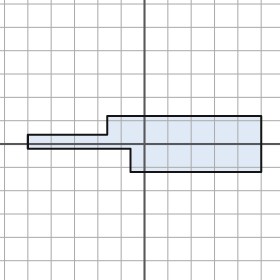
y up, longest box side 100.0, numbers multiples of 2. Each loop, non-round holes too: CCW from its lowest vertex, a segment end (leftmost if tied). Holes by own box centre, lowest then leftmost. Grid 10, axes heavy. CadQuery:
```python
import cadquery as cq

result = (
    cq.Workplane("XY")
    .moveTo(-6.0, -12.0)
    .lineTo(50.0, -12.0)
    .lineTo(50.0, 12.0)
    .lineTo(-16.0, 12.0)
    .lineTo(-16.0, 4.0)
    .lineTo(-50.0, 4.0)
    .lineTo(-50.0, -2.0)
    .lineTo(-6.0, -2.0)
    .close()
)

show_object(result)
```